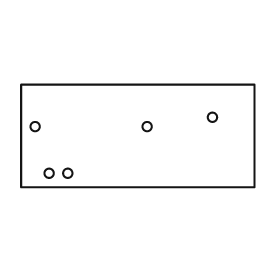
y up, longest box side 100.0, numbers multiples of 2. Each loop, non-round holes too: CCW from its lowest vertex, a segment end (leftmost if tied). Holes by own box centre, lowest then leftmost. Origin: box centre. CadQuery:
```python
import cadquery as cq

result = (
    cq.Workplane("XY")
    .moveTo(-50.0, -22.0)
    .lineTo(50.0, -22.0)
    .lineTo(50.0, 22.0)
    .lineTo(-50.0, 22.0)
    .close()
    .moveTo(-38.0, -16.0)
    .circle(2.0)
    .moveTo(-30.0, -16.0)
    .circle(2.0)
    .moveTo(-44.0, 4.0)
    .circle(2.0)
    .moveTo(4.0, 4.0)
    .circle(2.0)
    .moveTo(32.0, 8.0)
    .circle(2.0)
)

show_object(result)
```